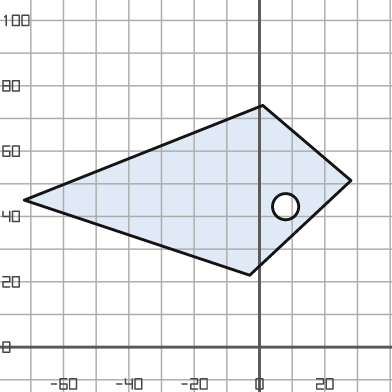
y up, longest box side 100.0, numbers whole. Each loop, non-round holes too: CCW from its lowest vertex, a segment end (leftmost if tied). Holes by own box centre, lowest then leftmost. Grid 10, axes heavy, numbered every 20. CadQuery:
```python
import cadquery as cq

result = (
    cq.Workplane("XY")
    .moveTo(-3.0, 22.0)
    .lineTo(28.0, 51.0)
    .lineTo(1.0, 74.0)
    .lineTo(-72.0, 45.0)
    .close()
    .moveTo(8.0, 43.0)
    .circle(4.0)
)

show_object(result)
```